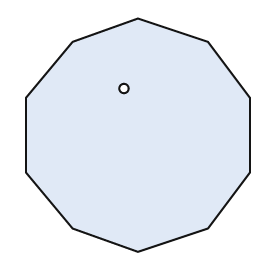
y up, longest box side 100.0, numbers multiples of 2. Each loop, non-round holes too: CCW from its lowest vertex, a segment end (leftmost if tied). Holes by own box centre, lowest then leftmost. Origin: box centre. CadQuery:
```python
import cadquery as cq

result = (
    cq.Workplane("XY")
    .moveTo(0.0, -50.0)
    .lineTo(30.0, -40.0)
    .lineTo(48.0, -16.0)
    .lineTo(48.0, 16.0)
    .lineTo(30.0, 40.0)
    .lineTo(0.0, 50.0)
    .lineTo(-28.0, 40.0)
    .lineTo(-48.0, 16.0)
    .lineTo(-48.0, -16.0)
    .lineTo(-28.0, -40.0)
    .close()
    .moveTo(-6.0, 20.0)
    .circle(2.0)
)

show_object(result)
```